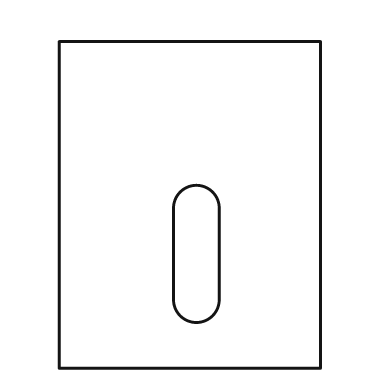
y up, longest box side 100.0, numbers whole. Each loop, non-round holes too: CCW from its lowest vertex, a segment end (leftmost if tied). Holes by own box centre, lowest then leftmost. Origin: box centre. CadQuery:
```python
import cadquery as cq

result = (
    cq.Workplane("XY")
    .moveTo(-40.0, -50.0)
    .lineTo(40.0, -50.0)
    .lineTo(40.0, 50.0)
    .lineTo(-40.0, 50.0)
    .close()
    .moveTo(-5.0, -29.0)
    .threePointArc((2.0, -36.0), (9.0, -29.0))
    .lineTo(9.0, -1.0)
    .threePointArc((2.0, 6.0), (-5.0, -1.0))
    .close()
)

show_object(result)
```